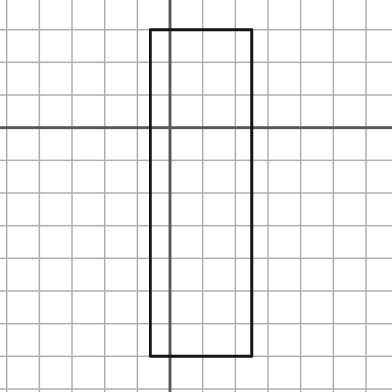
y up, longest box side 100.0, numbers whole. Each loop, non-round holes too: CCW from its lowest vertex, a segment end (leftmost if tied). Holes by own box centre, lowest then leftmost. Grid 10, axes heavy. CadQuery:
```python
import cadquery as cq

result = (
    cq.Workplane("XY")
    .moveTo(-6.0, -70.0)
    .lineTo(25.0, -70.0)
    .lineTo(25.0, 30.0)
    .lineTo(-6.0, 30.0)
    .close()
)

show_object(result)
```